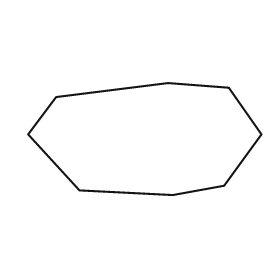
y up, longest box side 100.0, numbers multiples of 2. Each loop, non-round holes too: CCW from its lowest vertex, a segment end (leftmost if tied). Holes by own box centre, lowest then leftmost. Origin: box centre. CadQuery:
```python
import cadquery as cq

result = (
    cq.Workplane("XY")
    .moveTo(12.0, -24.0)
    .lineTo(34.0, -20.0)
    .lineTo(50.0, 2.0)
    .lineTo(36.0, 22.0)
    .lineTo(10.0, 24.0)
    .lineTo(-38.0, 18.0)
    .lineTo(-50.0, 2.0)
    .lineTo(-28.0, -22.0)
    .close()
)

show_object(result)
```